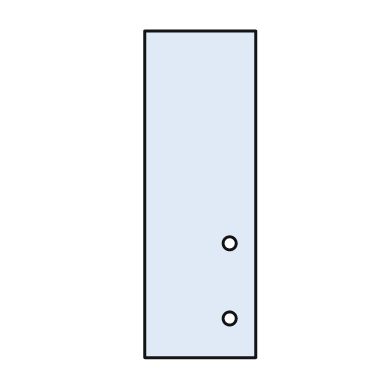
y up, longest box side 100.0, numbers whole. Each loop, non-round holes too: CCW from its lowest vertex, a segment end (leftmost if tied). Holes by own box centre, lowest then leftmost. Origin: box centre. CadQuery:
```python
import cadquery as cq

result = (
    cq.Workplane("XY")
    .moveTo(-17.0, -50.0)
    .lineTo(17.0, -50.0)
    .lineTo(17.0, 50.0)
    .lineTo(-17.0, 50.0)
    .close()
    .moveTo(9.0, -38.0)
    .circle(2.0)
    .moveTo(9.0, -15.0)
    .circle(2.0)
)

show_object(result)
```